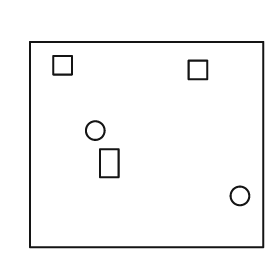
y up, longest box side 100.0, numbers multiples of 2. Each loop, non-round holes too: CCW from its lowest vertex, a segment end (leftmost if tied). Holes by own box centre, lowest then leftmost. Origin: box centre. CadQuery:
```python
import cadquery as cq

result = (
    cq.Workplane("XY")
    .moveTo(-50.0, -44.0)
    .lineTo(50.0, -44.0)
    .lineTo(50.0, 44.0)
    .lineTo(-50.0, 44.0)
    .close()
    .moveTo(40.0, -22.0)
    .circle(4.0)
    .moveTo(-20.0, -14.0)
    .lineTo(-12.0, -14.0)
    .lineTo(-12.0, -2.0)
    .lineTo(-20.0, -2.0)
    .close()
    .moveTo(-22.0, 6.0)
    .circle(4.0)
    .moveTo(18.0, 28.0)
    .lineTo(26.0, 28.0)
    .lineTo(26.0, 36.0)
    .lineTo(18.0, 36.0)
    .close()
    .moveTo(-40.0, 30.0)
    .lineTo(-32.0, 30.0)
    .lineTo(-32.0, 38.0)
    .lineTo(-40.0, 38.0)
    .close()
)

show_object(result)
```